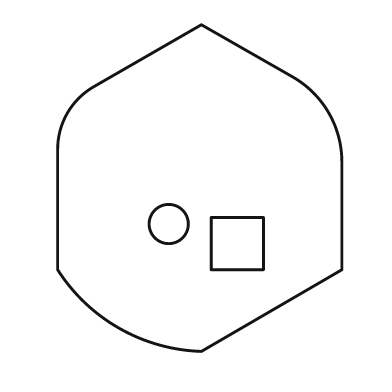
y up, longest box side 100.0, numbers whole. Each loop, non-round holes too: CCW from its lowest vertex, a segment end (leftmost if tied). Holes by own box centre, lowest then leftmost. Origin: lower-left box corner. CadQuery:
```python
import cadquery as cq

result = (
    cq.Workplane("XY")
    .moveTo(44.0, 0.0)
    .lineTo(87.0, 25.0)
    .lineTo(87.0, 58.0)
    .threePointArc((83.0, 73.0), (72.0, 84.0))
    .lineTo(44.0, 100.0)
    .lineTo(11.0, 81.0)
    .threePointArc((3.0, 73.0), (0.0, 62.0))
    .lineTo(0.0, 25.0)
    .threePointArc((19.0, 7.0), (44.0, 0.0))
    .close()
    .moveTo(47.0, 25.0)
    .lineTo(63.0, 25.0)
    .lineTo(63.0, 41.0)
    .lineTo(47.0, 41.0)
    .close()
    .moveTo(34.0, 39.0)
    .circle(6.0)
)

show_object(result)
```